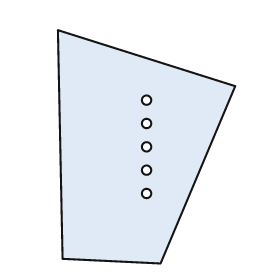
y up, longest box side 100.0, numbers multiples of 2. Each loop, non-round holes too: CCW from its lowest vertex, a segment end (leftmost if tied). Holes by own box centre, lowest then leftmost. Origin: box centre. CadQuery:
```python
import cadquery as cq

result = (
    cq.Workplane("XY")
    .moveTo(6.0, -50.0)
    .lineTo(38.0, 26.0)
    .lineTo(-38.0, 50.0)
    .lineTo(-36.0, -48.0)
    .close()
    .moveTo(0.0, -20.0)
    .circle(2.0)
    .moveTo(0.0, -10.0)
    .circle(2.0)
    .moveTo(0.0, 0.0)
    .circle(2.0)
    .moveTo(0.0, 10.0)
    .circle(2.0)
    .moveTo(0.0, 20.0)
    .circle(2.0)
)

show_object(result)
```